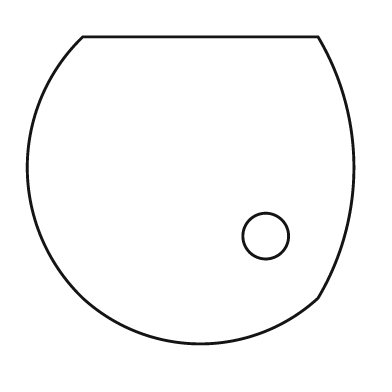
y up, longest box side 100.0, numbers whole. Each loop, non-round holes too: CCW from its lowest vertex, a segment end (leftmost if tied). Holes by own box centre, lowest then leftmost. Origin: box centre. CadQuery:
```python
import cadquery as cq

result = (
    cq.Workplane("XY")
    .moveTo(-33.0, -33.0)
    .threePointArc((3.0, -47.0), (39.0, -33.0))
    .threePointArc((50.0, 7.0), (39.0, 47.0))
    .lineTo(-33.0, 47.0)
    .threePointArc((-50.0, 7.0), (-33.0, -33.0))
    .close()
    .moveTo(23.0, -14.0)
    .circle(7.0)
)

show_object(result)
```